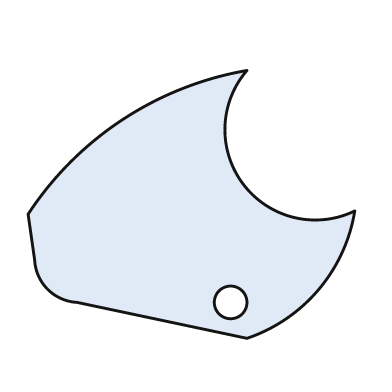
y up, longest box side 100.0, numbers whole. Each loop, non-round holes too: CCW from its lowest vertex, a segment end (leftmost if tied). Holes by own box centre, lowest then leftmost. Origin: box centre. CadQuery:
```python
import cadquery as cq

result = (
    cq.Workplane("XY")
    .moveTo(17.0, -41.0)
    .threePointArc((39.0, -26.0), (50.0, -2.0))
    .threePointArc((16.0, 6.0), (17.0, 41.0))
    .threePointArc((-21.0, 26.0), (-50.0, -3.0))
    .lineTo(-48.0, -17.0)
    .threePointArc((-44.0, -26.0), (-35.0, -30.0))
    .close()
    .moveTo(12.0, -30.0)
    .circle(5.0)
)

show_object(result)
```